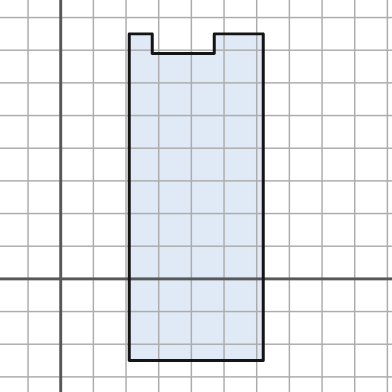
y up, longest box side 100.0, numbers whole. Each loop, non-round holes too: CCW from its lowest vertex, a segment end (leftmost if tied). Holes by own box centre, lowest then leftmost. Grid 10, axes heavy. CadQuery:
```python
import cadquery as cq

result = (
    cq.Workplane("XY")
    .moveTo(21.0, -25.0)
    .lineTo(62.0, -25.0)
    .lineTo(62.0, 75.0)
    .lineTo(47.0, 75.0)
    .lineTo(47.0, 69.0)
    .lineTo(28.0, 69.0)
    .lineTo(28.0, 75.0)
    .lineTo(21.0, 75.0)
    .close()
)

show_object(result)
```